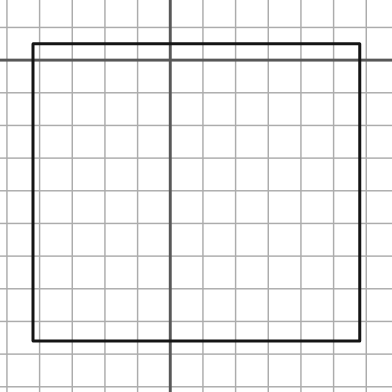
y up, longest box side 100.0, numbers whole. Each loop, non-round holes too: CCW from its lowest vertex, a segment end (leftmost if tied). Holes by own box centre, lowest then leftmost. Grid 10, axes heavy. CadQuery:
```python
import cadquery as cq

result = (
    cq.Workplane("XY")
    .moveTo(-42.0, -86.0)
    .lineTo(58.0, -86.0)
    .lineTo(58.0, 5.0)
    .lineTo(-42.0, 5.0)
    .close()
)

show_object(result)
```